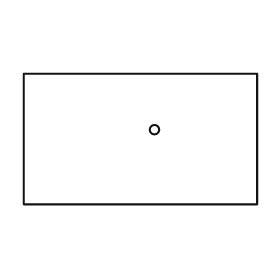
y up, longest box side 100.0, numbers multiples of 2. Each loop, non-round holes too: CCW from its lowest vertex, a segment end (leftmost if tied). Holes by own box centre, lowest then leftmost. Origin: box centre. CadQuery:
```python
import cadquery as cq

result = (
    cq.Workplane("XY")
    .moveTo(-50.0, -28.0)
    .lineTo(50.0, -28.0)
    .lineTo(50.0, 28.0)
    .lineTo(-50.0, 28.0)
    .close()
    .moveTo(6.0, 4.0)
    .circle(2.0)
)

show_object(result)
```